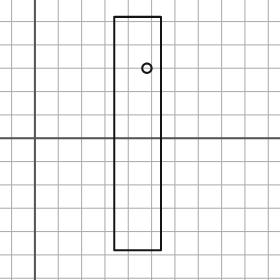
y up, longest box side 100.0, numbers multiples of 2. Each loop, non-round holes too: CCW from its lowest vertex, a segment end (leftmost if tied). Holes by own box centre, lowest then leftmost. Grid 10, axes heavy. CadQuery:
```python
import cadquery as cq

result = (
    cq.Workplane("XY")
    .moveTo(34.0, -48.0)
    .lineTo(54.0, -48.0)
    .lineTo(54.0, 52.0)
    .lineTo(34.0, 52.0)
    .close()
    .moveTo(48.0, 30.0)
    .circle(2.0)
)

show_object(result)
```